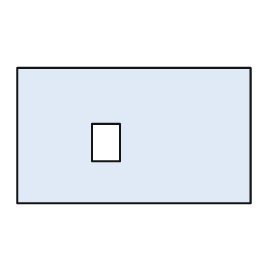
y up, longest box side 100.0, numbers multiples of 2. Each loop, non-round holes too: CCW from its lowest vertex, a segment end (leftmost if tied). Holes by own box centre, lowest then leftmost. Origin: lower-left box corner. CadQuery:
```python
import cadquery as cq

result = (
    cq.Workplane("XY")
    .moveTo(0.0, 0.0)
    .lineTo(100.0, 0.0)
    .lineTo(100.0, 58.0)
    .lineTo(0.0, 58.0)
    .close()
    .moveTo(32.0, 18.0)
    .lineTo(44.0, 18.0)
    .lineTo(44.0, 34.0)
    .lineTo(32.0, 34.0)
    .close()
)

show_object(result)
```